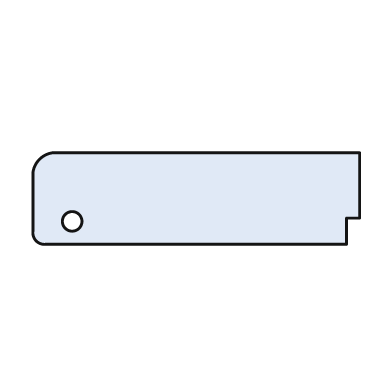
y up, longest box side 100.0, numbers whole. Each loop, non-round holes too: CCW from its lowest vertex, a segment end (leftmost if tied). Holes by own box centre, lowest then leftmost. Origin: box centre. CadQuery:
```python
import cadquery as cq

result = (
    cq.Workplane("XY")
    .moveTo(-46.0, -14.0)
    .lineTo(46.0, -14.0)
    .lineTo(46.0, -6.0)
    .lineTo(50.0, -6.0)
    .lineTo(50.0, 14.0)
    .lineTo(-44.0, 14.0)
    .threePointArc((-48.0, 12.0), (-50.0, 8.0))
    .lineTo(-50.0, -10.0)
    .threePointArc((-49.0, -13.0), (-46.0, -14.0))
    .close()
    .moveTo(-38.0, -7.0)
    .circle(3.0)
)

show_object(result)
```